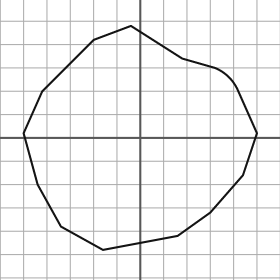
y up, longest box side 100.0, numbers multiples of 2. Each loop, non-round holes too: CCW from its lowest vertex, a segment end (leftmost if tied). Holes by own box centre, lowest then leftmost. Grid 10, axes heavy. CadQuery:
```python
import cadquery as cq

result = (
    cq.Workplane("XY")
    .moveTo(-16.0, -48.0)
    .lineTo(16.0, -42.0)
    .lineTo(30.0, -32.0)
    .lineTo(44.0, -16.0)
    .lineTo(50.0, 2.0)
    .lineTo(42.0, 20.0)
    .threePointArc((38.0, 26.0), (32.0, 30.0))
    .lineTo(18.0, 34.0)
    .lineTo(-4.0, 48.0)
    .lineTo(-20.0, 42.0)
    .lineTo(-42.0, 20.0)
    .lineTo(-50.0, 2.0)
    .lineTo(-44.0, -20.0)
    .lineTo(-34.0, -38.0)
    .close()
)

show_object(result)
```